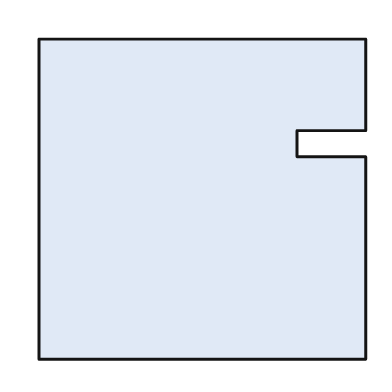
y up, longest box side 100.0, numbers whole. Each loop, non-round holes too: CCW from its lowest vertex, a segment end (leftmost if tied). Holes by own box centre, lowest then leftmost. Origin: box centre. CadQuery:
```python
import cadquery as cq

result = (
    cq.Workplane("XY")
    .moveTo(-50.0, -49.0)
    .lineTo(50.0, -49.0)
    .lineTo(50.0, 13.0)
    .lineTo(29.0, 13.0)
    .lineTo(29.0, 21.0)
    .lineTo(50.0, 21.0)
    .lineTo(50.0, 49.0)
    .lineTo(-50.0, 49.0)
    .close()
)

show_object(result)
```